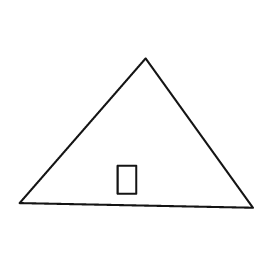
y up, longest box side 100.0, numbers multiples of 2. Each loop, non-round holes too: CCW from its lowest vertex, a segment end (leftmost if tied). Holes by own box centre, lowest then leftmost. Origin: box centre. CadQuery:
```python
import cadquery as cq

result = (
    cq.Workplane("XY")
    .moveTo(50.0, -32.0)
    .lineTo(4.0, 32.0)
    .lineTo(-50.0, -30.0)
    .close()
    .moveTo(-8.0, -26.0)
    .lineTo(0.0, -26.0)
    .lineTo(0.0, -14.0)
    .lineTo(-8.0, -14.0)
    .close()
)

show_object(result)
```